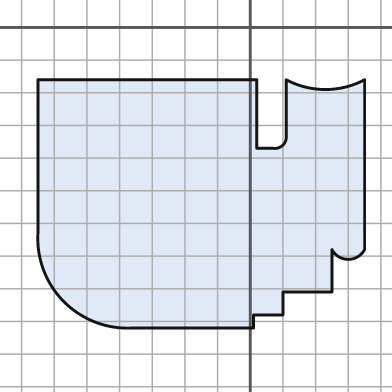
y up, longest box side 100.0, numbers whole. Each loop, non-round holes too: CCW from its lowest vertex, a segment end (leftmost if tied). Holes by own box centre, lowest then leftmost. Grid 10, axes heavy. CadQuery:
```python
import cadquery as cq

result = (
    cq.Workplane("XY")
    .moveTo(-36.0, -92.0)
    .lineTo(1.0, -92.0)
    .lineTo(1.0, -88.0)
    .lineTo(10.0, -88.0)
    .lineTo(10.0, -81.0)
    .lineTo(25.0, -81.0)
    .lineTo(25.0, -68.0)
    .threePointArc((30.0, -71.0), (35.0, -68.0))
    .lineTo(35.0, -16.0)
    .threePointArc((23.0, -19.0), (11.0, -16.0))
    .lineTo(11.0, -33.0)
    .threePointArc((10.0, -36.0), (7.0, -37.0))
    .lineTo(2.0, -37.0)
    .lineTo(2.0, -16.0)
    .lineTo(-65.0, -16.0)
    .lineTo(-65.0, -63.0)
    .threePointArc((-57.0, -84.0), (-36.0, -92.0))
    .close()
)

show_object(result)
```